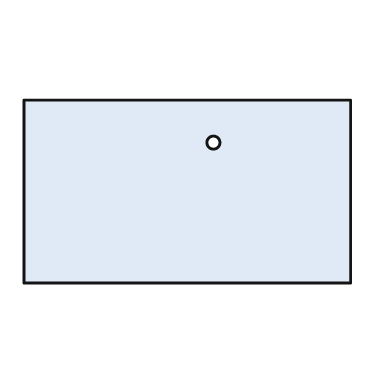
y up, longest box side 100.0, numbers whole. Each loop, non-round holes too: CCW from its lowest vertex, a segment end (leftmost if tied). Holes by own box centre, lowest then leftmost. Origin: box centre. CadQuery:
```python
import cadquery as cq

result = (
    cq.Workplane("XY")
    .moveTo(-50.0, -28.0)
    .lineTo(50.0, -28.0)
    .lineTo(50.0, 28.0)
    .lineTo(-50.0, 28.0)
    .close()
    .moveTo(8.0, 15.0)
    .circle(2.0)
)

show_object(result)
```